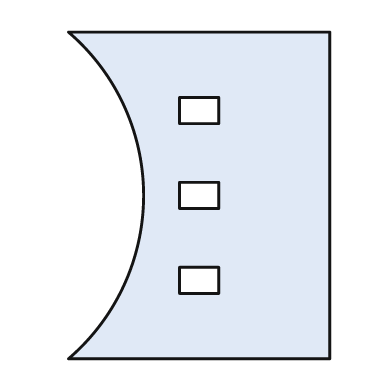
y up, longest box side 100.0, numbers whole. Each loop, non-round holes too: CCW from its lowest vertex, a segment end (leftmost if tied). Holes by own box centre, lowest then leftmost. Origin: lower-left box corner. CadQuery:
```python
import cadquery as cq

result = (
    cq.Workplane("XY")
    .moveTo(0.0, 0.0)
    .lineTo(80.0, 0.0)
    .lineTo(80.0, 100.0)
    .lineTo(0.0, 100.0)
    .threePointArc((23.0, 50.0), (0.0, 0.0))
    .close()
    .moveTo(34.0, 20.0)
    .lineTo(46.0, 20.0)
    .lineTo(46.0, 28.0)
    .lineTo(34.0, 28.0)
    .close()
    .moveTo(34.0, 46.0)
    .lineTo(46.0, 46.0)
    .lineTo(46.0, 54.0)
    .lineTo(34.0, 54.0)
    .close()
    .moveTo(34.0, 72.0)
    .lineTo(46.0, 72.0)
    .lineTo(46.0, 80.0)
    .lineTo(34.0, 80.0)
    .close()
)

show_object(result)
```